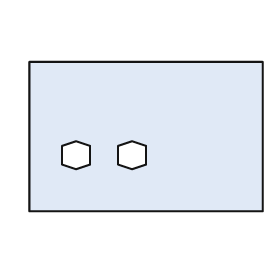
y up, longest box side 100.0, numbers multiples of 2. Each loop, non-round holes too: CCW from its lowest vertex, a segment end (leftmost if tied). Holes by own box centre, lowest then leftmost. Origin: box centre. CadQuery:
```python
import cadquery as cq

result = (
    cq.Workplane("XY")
    .moveTo(-50.0, -32.0)
    .lineTo(50.0, -32.0)
    .lineTo(50.0, 32.0)
    .lineTo(-50.0, 32.0)
    .close()
    .moveTo(-30.0, -14.0)
    .lineTo(-24.0, -12.0)
    .lineTo(-24.0, -4.0)
    .lineTo(-30.0, -2.0)
    .lineTo(-36.0, -4.0)
    .lineTo(-36.0, -12.0)
    .close()
    .moveTo(-6.0, -14.0)
    .lineTo(0.0, -12.0)
    .lineTo(0.0, -4.0)
    .lineTo(-6.0, -2.0)
    .lineTo(-12.0, -4.0)
    .lineTo(-12.0, -12.0)
    .close()
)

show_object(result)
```